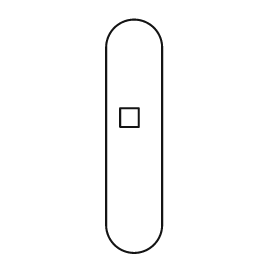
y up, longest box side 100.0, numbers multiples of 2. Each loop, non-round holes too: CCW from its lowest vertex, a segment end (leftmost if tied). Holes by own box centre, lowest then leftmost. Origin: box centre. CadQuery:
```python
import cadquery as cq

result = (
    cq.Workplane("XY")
    .moveTo(-12.0, -38.0)
    .threePointArc((0.0, -50.0), (12.0, -38.0))
    .lineTo(12.0, 38.0)
    .threePointArc((0.0, 50.0), (-12.0, 38.0))
    .close()
    .moveTo(-6.0, 4.0)
    .lineTo(2.0, 4.0)
    .lineTo(2.0, 12.0)
    .lineTo(-6.0, 12.0)
    .close()
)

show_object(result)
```